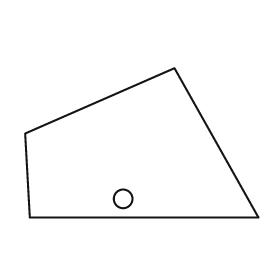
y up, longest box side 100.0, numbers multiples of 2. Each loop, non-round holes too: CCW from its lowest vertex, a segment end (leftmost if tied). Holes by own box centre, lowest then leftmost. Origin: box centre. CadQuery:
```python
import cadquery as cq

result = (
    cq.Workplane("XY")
    .moveTo(-48.0, -32.0)
    .lineTo(50.0, -32.0)
    .lineTo(14.0, 32.0)
    .lineTo(-50.0, 4.0)
    .close()
    .moveTo(-8.0, -24.0)
    .circle(4.0)
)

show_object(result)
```